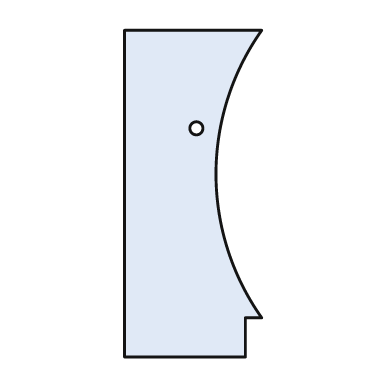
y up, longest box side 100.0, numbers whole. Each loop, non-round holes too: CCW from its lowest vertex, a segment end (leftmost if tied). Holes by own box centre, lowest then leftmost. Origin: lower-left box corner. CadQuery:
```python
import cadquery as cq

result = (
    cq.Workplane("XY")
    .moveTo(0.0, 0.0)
    .lineTo(37.0, 0.0)
    .lineTo(37.0, 12.0)
    .lineTo(42.0, 12.0)
    .threePointArc((28.0, 56.0), (42.0, 100.0))
    .lineTo(0.0, 100.0)
    .close()
    .moveTo(22.0, 70.0)
    .circle(2.0)
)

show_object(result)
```